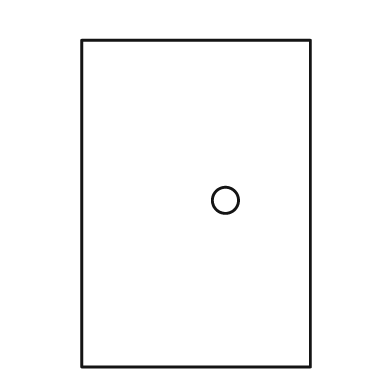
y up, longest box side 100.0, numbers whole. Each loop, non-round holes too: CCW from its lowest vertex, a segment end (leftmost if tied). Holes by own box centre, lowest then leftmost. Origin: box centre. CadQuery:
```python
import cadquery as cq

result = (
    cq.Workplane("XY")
    .moveTo(-35.0, -50.0)
    .lineTo(35.0, -50.0)
    .lineTo(35.0, 50.0)
    .lineTo(-35.0, 50.0)
    .close()
    .moveTo(9.0, 1.0)
    .circle(4.0)
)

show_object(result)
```